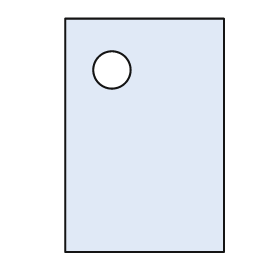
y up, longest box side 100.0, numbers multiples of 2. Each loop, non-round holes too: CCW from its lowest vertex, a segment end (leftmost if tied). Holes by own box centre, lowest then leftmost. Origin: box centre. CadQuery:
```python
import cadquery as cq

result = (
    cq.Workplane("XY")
    .moveTo(-34.0, -50.0)
    .lineTo(34.0, -50.0)
    .lineTo(34.0, 50.0)
    .lineTo(-34.0, 50.0)
    .close()
    .moveTo(-14.0, 28.0)
    .circle(8.0)
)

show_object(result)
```